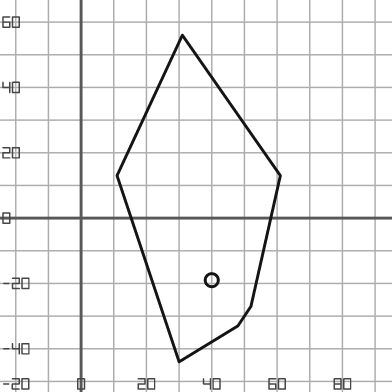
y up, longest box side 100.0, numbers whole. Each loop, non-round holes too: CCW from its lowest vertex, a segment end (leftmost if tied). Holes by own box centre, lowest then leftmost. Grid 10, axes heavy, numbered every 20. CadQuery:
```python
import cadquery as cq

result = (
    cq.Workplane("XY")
    .moveTo(30.0, -44.0)
    .lineTo(48.0, -33.0)
    .lineTo(52.0, -27.0)
    .lineTo(61.0, 13.0)
    .lineTo(31.0, 56.0)
    .lineTo(11.0, 13.0)
    .close()
    .moveTo(40.0, -19.0)
    .circle(2.0)
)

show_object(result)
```